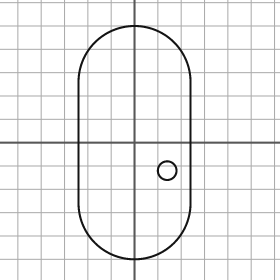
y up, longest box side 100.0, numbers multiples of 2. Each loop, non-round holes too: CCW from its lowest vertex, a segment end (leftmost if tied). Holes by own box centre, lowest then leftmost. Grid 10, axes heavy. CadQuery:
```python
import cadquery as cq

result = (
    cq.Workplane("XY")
    .moveTo(-24.0, -26.0)
    .threePointArc((0.0, -50.0), (24.0, -26.0))
    .lineTo(24.0, 26.0)
    .threePointArc((0.0, 50.0), (-24.0, 26.0))
    .close()
    .moveTo(14.0, -12.0)
    .circle(4.0)
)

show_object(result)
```